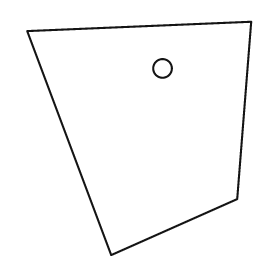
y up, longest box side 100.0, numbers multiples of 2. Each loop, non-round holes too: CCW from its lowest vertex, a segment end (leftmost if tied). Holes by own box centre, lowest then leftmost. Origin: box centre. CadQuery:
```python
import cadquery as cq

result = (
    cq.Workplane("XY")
    .moveTo(-12.0, -50.0)
    .lineTo(42.0, -26.0)
    .lineTo(48.0, 50.0)
    .lineTo(-48.0, 46.0)
    .close()
    .moveTo(10.0, 30.0)
    .circle(4.0)
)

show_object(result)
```